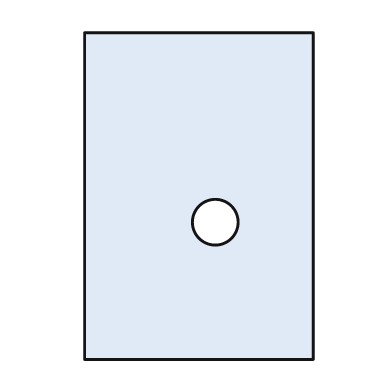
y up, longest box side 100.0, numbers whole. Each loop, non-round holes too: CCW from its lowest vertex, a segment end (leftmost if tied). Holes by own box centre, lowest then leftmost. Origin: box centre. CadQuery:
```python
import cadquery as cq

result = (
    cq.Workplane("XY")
    .moveTo(-35.0, -50.0)
    .lineTo(35.0, -50.0)
    .lineTo(35.0, 50.0)
    .lineTo(-35.0, 50.0)
    .close()
    .moveTo(5.0, -8.0)
    .circle(7.0)
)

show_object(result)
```